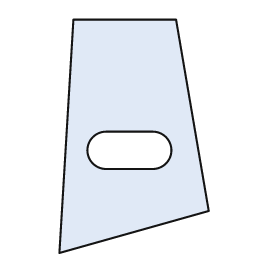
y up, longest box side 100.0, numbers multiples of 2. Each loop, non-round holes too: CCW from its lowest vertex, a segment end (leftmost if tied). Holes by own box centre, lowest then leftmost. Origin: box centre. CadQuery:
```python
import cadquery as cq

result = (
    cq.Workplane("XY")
    .moveTo(-32.0, -50.0)
    .lineTo(32.0, -32.0)
    .lineTo(18.0, 50.0)
    .lineTo(-26.0, 50.0)
    .close()
    .moveTo(-12.0, -14.0)
    .lineTo(8.0, -14.0)
    .threePointArc((16.0, -6.0), (8.0, 2.0))
    .lineTo(-12.0, 2.0)
    .threePointArc((-20.0, -6.0), (-12.0, -14.0))
    .close()
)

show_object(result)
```